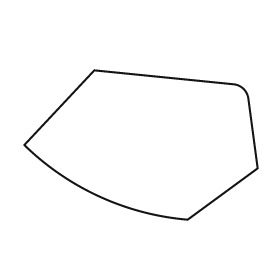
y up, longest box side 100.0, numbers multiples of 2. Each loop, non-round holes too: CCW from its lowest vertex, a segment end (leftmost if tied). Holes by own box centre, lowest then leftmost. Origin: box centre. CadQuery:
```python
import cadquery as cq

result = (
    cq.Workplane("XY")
    .moveTo(20.0, -32.0)
    .lineTo(50.0, -10.0)
    .lineTo(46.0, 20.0)
    .threePointArc((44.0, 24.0), (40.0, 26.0))
    .lineTo(-20.0, 32.0)
    .lineTo(-50.0, 0.0)
    .threePointArc((-18.0, -22.0), (20.0, -32.0))
    .close()
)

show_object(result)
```